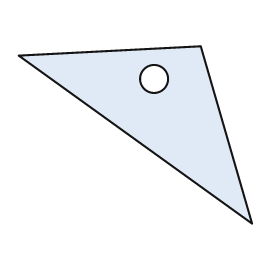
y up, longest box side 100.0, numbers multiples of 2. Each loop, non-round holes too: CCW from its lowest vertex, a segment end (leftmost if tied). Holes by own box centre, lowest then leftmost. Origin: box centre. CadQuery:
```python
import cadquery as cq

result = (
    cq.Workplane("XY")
    .moveTo(50.0, -38.0)
    .lineTo(28.0, 38.0)
    .lineTo(-50.0, 34.0)
    .close()
    .moveTo(8.0, 24.0)
    .circle(6.0)
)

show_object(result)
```